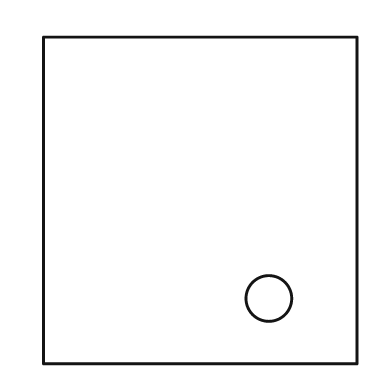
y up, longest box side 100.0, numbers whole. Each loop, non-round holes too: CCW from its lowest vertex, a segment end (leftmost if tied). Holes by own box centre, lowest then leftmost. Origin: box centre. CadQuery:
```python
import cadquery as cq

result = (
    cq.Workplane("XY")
    .moveTo(-48.0, -50.0)
    .lineTo(48.0, -50.0)
    .lineTo(48.0, 50.0)
    .lineTo(-48.0, 50.0)
    .close()
    .moveTo(21.0, -30.0)
    .circle(7.0)
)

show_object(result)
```